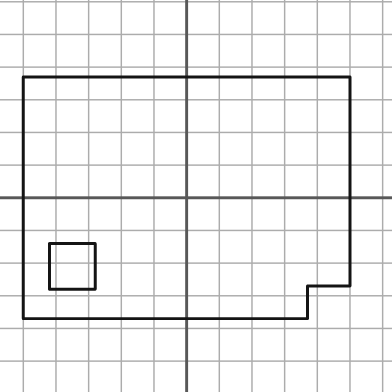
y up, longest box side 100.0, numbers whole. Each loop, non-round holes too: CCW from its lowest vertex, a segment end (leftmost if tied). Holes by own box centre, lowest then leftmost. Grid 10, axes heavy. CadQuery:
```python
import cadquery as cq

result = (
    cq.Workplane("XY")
    .moveTo(-50.0, -37.0)
    .lineTo(37.0, -37.0)
    .lineTo(37.0, -27.0)
    .lineTo(50.0, -27.0)
    .lineTo(50.0, 37.0)
    .lineTo(-50.0, 37.0)
    .close()
    .moveTo(-42.0, -28.0)
    .lineTo(-28.0, -28.0)
    .lineTo(-28.0, -14.0)
    .lineTo(-42.0, -14.0)
    .close()
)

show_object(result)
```